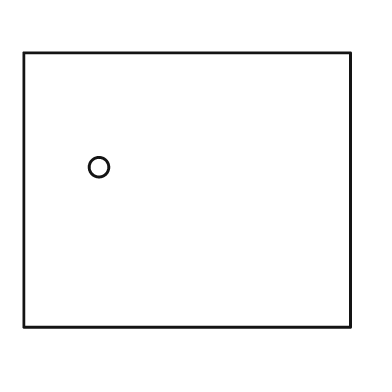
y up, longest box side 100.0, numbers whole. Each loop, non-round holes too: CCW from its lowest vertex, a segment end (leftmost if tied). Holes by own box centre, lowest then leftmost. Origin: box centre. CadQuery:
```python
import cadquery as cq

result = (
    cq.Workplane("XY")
    .moveTo(-50.0, -42.0)
    .lineTo(50.0, -42.0)
    .lineTo(50.0, 42.0)
    .lineTo(-50.0, 42.0)
    .close()
    .moveTo(-27.0, 7.0)
    .circle(3.0)
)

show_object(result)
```